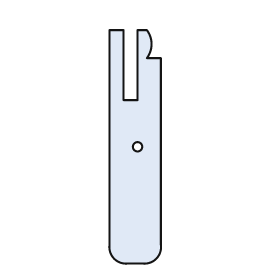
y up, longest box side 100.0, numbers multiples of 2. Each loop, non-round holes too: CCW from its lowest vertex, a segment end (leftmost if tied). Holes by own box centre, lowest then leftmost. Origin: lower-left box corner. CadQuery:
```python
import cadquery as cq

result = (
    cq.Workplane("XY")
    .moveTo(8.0, 0.0)
    .lineTo(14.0, 0.0)
    .threePointArc((20.0, 2.0), (22.0, 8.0))
    .lineTo(22.0, 88.0)
    .lineTo(16.0, 88.0)
    .threePointArc((18.0, 94.0), (16.0, 100.0))
    .lineTo(12.0, 100.0)
    .lineTo(12.0, 70.0)
    .lineTo(6.0, 70.0)
    .lineTo(6.0, 100.0)
    .lineTo(0.0, 100.0)
    .lineTo(0.0, 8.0)
    .threePointArc((2.0, 2.0), (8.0, 0.0))
    .close()
    .moveTo(12.0, 50.0)
    .circle(2.0)
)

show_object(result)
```